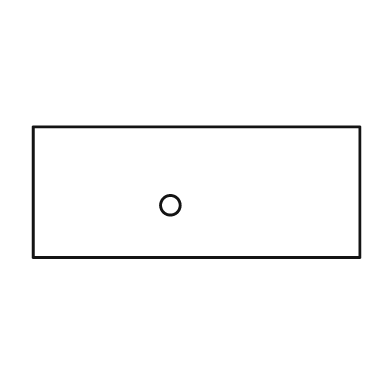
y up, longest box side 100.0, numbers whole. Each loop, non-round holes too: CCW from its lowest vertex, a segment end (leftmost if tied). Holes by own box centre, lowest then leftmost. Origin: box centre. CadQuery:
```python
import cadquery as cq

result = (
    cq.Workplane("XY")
    .moveTo(-50.0, -20.0)
    .lineTo(50.0, -20.0)
    .lineTo(50.0, 20.0)
    .lineTo(-50.0, 20.0)
    .close()
    .moveTo(-8.0, -4.0)
    .circle(3.0)
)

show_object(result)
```